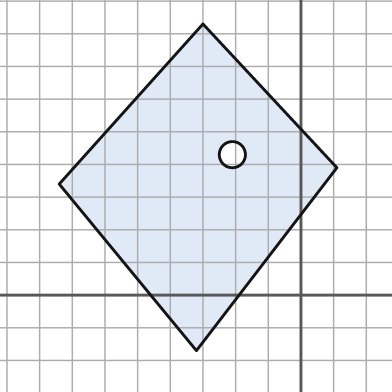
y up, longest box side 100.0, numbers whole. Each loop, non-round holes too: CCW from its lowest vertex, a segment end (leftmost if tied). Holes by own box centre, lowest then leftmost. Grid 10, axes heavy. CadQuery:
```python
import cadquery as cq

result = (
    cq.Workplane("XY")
    .moveTo(-32.0, -17.0)
    .lineTo(11.0, 39.0)
    .lineTo(-30.0, 83.0)
    .lineTo(-74.0, 34.0)
    .close()
    .moveTo(-21.0, 43.0)
    .circle(4.0)
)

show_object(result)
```